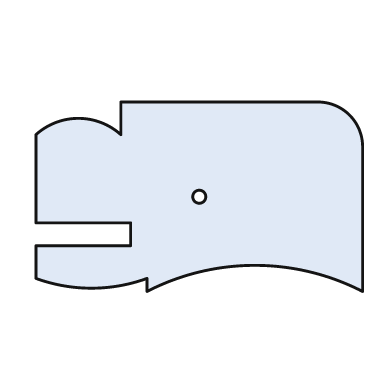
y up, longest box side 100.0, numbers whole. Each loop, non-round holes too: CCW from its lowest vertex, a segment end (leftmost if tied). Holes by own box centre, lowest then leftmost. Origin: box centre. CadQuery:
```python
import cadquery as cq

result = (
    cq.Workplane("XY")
    .moveTo(-16.0, -29.0)
    .threePointArc((17.0, -21.0), (50.0, -29.0))
    .lineTo(50.0, 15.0)
    .threePointArc((46.0, 25.0), (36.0, 29.0))
    .lineTo(-24.0, 29.0)
    .lineTo(-24.0, 19.0)
    .threePointArc((-37.0, 24.0), (-50.0, 19.0))
    .lineTo(-50.0, -8.0)
    .lineTo(-21.0, -8.0)
    .lineTo(-21.0, -15.0)
    .lineTo(-50.0, -15.0)
    .lineTo(-50.0, -25.0)
    .threePointArc((-33.0, -28.0), (-16.0, -25.0))
    .close()
    .moveTo(0.0, 0.0)
    .circle(2.0)
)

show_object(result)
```